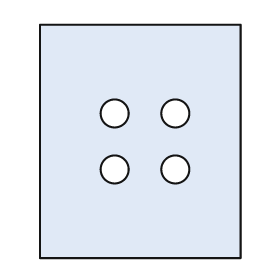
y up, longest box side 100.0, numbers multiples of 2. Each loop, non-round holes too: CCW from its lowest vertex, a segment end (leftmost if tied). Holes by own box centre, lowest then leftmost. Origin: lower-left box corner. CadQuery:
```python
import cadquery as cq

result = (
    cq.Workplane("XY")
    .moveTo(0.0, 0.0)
    .lineTo(86.0, 0.0)
    .lineTo(86.0, 100.0)
    .lineTo(0.0, 100.0)
    .close()
    .moveTo(32.0, 38.0)
    .circle(6.0)
    .moveTo(58.0, 38.0)
    .circle(6.0)
    .moveTo(32.0, 62.0)
    .circle(6.0)
    .moveTo(58.0, 62.0)
    .circle(6.0)
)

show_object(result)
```